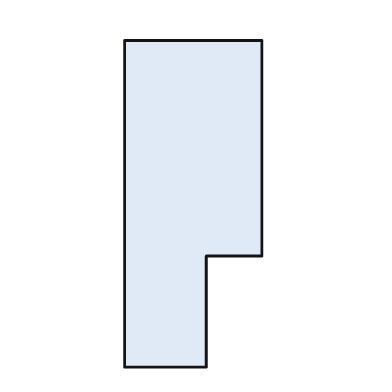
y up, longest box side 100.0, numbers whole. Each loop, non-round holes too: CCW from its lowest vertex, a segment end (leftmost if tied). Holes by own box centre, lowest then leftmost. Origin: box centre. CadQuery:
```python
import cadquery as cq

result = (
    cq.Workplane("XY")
    .moveTo(-21.0, -50.0)
    .lineTo(4.0, -50.0)
    .lineTo(4.0, -16.0)
    .lineTo(21.0, -16.0)
    .lineTo(21.0, 50.0)
    .lineTo(-21.0, 50.0)
    .close()
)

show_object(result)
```